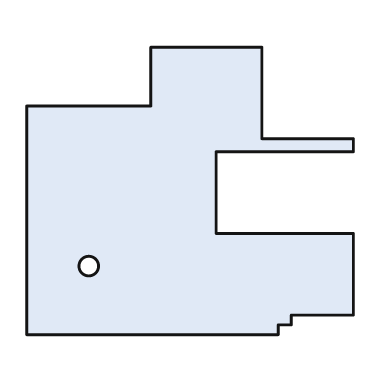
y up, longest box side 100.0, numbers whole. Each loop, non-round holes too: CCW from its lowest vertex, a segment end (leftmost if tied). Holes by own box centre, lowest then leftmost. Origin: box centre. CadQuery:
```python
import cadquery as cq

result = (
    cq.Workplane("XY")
    .moveTo(-50.0, -44.0)
    .lineTo(27.0, -44.0)
    .lineTo(27.0, -41.0)
    .lineTo(31.0, -41.0)
    .lineTo(31.0, -38.0)
    .lineTo(50.0, -38.0)
    .lineTo(50.0, -13.0)
    .lineTo(8.0, -13.0)
    .lineTo(8.0, 12.0)
    .lineTo(50.0, 12.0)
    .lineTo(50.0, 16.0)
    .lineTo(22.0, 16.0)
    .lineTo(22.0, 44.0)
    .lineTo(-12.0, 44.0)
    .lineTo(-12.0, 26.0)
    .lineTo(-50.0, 26.0)
    .close()
    .moveTo(-31.0, -23.0)
    .circle(3.0)
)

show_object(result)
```